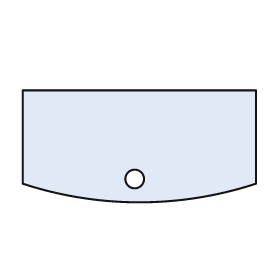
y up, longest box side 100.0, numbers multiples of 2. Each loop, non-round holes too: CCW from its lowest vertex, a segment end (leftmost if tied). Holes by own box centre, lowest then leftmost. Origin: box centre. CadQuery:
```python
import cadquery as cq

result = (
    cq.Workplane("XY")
    .moveTo(-50.0, -16.0)
    .threePointArc((0.0, -24.0), (50.0, -16.0))
    .lineTo(50.0, 24.0)
    .lineTo(-50.0, 24.0)
    .close()
    .moveTo(-2.0, -14.0)
    .circle(4.0)
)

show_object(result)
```